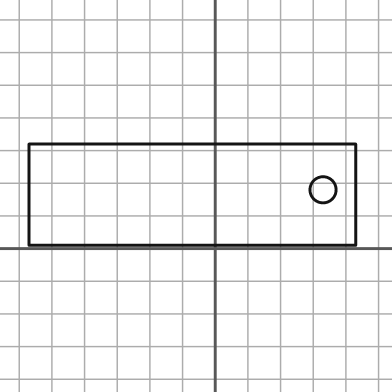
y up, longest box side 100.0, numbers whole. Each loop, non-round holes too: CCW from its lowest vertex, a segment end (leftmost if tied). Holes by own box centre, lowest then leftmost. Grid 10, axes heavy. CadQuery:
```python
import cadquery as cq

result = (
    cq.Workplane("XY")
    .moveTo(-57.0, 1.0)
    .lineTo(43.0, 1.0)
    .lineTo(43.0, 32.0)
    .lineTo(-57.0, 32.0)
    .close()
    .moveTo(33.0, 18.0)
    .circle(4.0)
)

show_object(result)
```